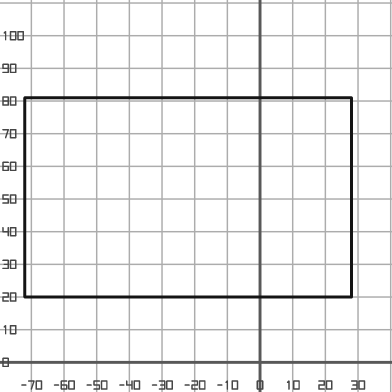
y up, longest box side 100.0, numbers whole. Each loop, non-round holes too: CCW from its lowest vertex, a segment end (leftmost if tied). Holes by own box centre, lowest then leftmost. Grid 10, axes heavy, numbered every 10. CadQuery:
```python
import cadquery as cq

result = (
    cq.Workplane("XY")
    .moveTo(-72.0, 20.0)
    .lineTo(28.0, 20.0)
    .lineTo(28.0, 81.0)
    .lineTo(-72.0, 81.0)
    .close()
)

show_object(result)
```